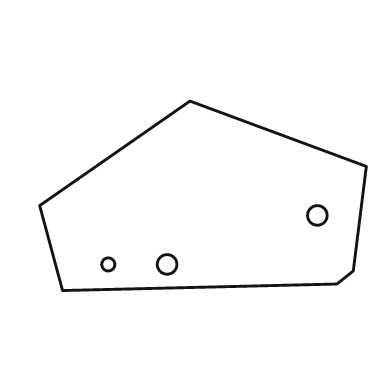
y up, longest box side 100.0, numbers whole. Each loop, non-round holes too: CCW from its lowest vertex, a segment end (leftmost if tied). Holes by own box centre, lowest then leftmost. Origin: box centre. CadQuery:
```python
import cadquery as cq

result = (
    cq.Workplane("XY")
    .moveTo(-43.0, -29.0)
    .lineTo(41.0, -27.0)
    .lineTo(46.0, -23.0)
    .lineTo(50.0, 9.0)
    .lineTo(-4.0, 29.0)
    .lineTo(-50.0, -3.0)
    .close()
    .moveTo(-29.0, -21.0)
    .circle(2.0)
    .moveTo(-11.0, -21.0)
    .circle(3.0)
    .moveTo(35.0, -6.0)
    .circle(3.0)
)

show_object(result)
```